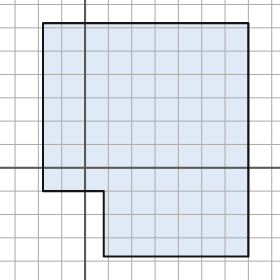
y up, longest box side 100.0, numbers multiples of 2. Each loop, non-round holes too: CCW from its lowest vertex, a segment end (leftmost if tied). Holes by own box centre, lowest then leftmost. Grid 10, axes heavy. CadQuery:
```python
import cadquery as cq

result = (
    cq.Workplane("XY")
    .moveTo(8.0, -38.0)
    .lineTo(70.0, -38.0)
    .lineTo(70.0, 62.0)
    .lineTo(-18.0, 62.0)
    .lineTo(-18.0, -10.0)
    .lineTo(8.0, -10.0)
    .close()
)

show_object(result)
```